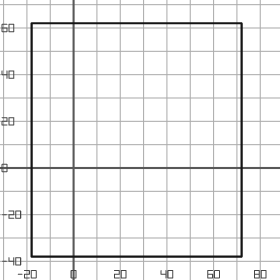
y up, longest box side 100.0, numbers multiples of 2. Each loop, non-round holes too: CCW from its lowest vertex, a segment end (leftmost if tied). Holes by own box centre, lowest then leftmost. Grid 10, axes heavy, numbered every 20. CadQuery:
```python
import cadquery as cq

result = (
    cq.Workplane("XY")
    .moveTo(-18.0, -38.0)
    .lineTo(72.0, -38.0)
    .lineTo(72.0, 62.0)
    .lineTo(-18.0, 62.0)
    .close()
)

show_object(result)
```